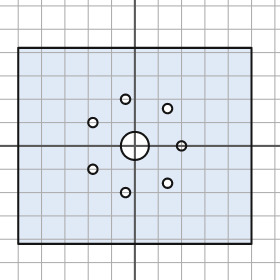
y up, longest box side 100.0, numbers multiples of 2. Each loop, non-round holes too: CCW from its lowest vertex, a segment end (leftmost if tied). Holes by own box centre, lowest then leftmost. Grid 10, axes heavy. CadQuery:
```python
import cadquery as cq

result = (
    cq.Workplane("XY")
    .moveTo(-50.0, -42.0)
    .lineTo(50.0, -42.0)
    .lineTo(50.0, 42.0)
    .lineTo(-50.0, 42.0)
    .close()
    .moveTo(-4.0, -20.0)
    .circle(2.0)
    .moveTo(14.0, -16.0)
    .circle(2.0)
    .moveTo(-18.0, -10.0)
    .circle(2.0)
    .moveTo(0.0, 0.0)
    .circle(6.0)
    .moveTo(20.0, 0.0)
    .circle(2.0)
    .moveTo(-18.0, 10.0)
    .circle(2.0)
    .moveTo(14.0, 16.0)
    .circle(2.0)
    .moveTo(-4.0, 20.0)
    .circle(2.0)
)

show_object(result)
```